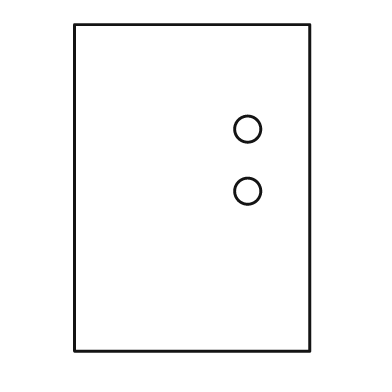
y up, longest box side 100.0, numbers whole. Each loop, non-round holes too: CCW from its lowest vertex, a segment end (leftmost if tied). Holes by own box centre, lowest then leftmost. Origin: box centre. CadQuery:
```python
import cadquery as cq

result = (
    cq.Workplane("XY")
    .moveTo(-36.0, -50.0)
    .lineTo(36.0, -50.0)
    .lineTo(36.0, 50.0)
    .lineTo(-36.0, 50.0)
    .close()
    .moveTo(17.0, -1.0)
    .circle(4.0)
    .moveTo(17.0, 18.0)
    .circle(4.0)
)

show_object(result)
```